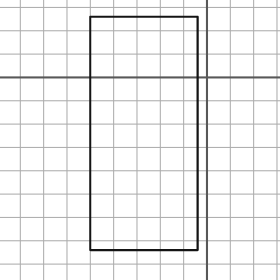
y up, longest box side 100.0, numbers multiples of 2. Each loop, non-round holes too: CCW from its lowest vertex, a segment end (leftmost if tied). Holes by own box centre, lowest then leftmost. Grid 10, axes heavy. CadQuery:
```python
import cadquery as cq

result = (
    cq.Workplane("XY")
    .moveTo(-50.0, -74.0)
    .lineTo(-4.0, -74.0)
    .lineTo(-4.0, 26.0)
    .lineTo(-50.0, 26.0)
    .close()
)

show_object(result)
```